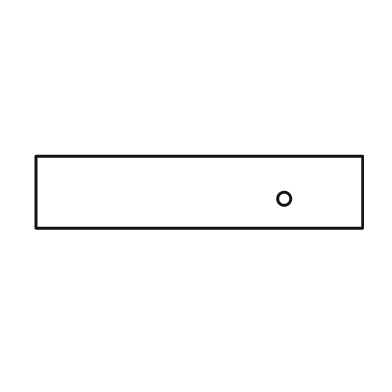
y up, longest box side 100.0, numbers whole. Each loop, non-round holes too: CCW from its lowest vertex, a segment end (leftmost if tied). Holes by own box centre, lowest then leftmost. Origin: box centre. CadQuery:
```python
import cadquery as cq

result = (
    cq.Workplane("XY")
    .moveTo(-50.0, -11.0)
    .lineTo(50.0, -11.0)
    .lineTo(50.0, 11.0)
    .lineTo(-50.0, 11.0)
    .close()
    .moveTo(26.0, -2.0)
    .circle(2.0)
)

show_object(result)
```